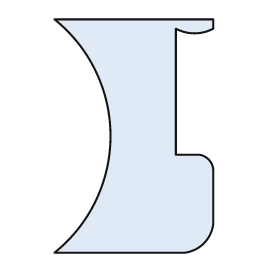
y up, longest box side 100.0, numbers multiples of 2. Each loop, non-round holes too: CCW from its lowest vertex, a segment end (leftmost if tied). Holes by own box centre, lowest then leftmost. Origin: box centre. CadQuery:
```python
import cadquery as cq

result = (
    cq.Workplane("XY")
    .moveTo(-34.0, -50.0)
    .lineTo(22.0, -50.0)
    .threePointArc((30.0, -46.0), (34.0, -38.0))
    .lineTo(34.0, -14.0)
    .threePointArc((32.0, -10.0), (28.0, -8.0))
    .lineTo(18.0, -8.0)
    .lineTo(18.0, 46.0)
    .threePointArc((26.0, 44.0), (34.0, 46.0))
    .lineTo(34.0, 50.0)
    .lineTo(-34.0, 50.0)
    .threePointArc((-10.0, 0.0), (-34.0, -50.0))
    .close()
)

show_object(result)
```